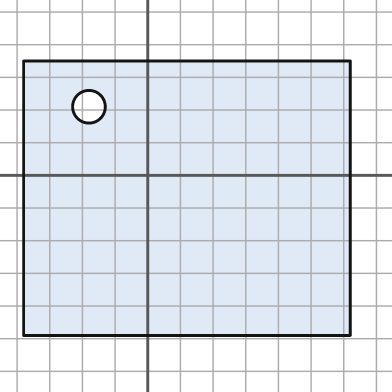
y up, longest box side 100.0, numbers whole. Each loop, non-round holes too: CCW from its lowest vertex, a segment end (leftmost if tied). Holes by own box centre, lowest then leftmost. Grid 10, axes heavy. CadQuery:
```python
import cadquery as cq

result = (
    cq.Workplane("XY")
    .moveTo(-38.0, -49.0)
    .lineTo(62.0, -49.0)
    .lineTo(62.0, 35.0)
    .lineTo(-38.0, 35.0)
    .close()
    .moveTo(-18.0, 21.0)
    .circle(5.0)
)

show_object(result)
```